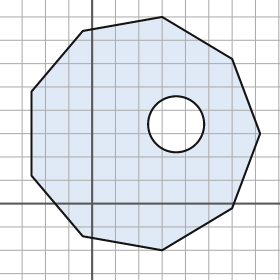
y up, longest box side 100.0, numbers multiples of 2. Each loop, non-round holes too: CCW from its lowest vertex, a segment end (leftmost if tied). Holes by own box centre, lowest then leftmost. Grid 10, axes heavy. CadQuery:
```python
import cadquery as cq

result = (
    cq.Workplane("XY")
    .moveTo(30.0, -20.0)
    .lineTo(60.0, -2.0)
    .lineTo(72.0, 30.0)
    .lineTo(60.0, 62.0)
    .lineTo(30.0, 80.0)
    .lineTo(-4.0, 74.0)
    .lineTo(-26.0, 48.0)
    .lineTo(-26.0, 12.0)
    .lineTo(-4.0, -14.0)
    .close()
    .moveTo(36.0, 34.0)
    .circle(12.0)
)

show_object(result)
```